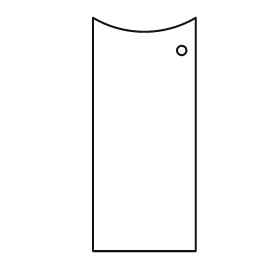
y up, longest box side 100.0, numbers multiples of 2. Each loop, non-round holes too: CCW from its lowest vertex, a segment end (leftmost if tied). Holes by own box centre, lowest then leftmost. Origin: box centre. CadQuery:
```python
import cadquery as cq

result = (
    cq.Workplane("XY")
    .moveTo(-22.0, -50.0)
    .lineTo(22.0, -50.0)
    .lineTo(22.0, 50.0)
    .threePointArc((0.0, 44.0), (-22.0, 50.0))
    .close()
    .moveTo(16.0, 36.0)
    .circle(2.0)
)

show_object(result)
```